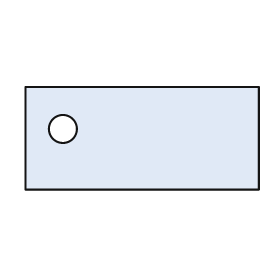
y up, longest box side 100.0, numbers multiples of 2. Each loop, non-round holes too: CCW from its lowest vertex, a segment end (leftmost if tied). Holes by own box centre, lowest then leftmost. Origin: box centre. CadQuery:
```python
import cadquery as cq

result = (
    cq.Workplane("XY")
    .moveTo(-50.0, -22.0)
    .lineTo(50.0, -22.0)
    .lineTo(50.0, 22.0)
    .lineTo(-50.0, 22.0)
    .close()
    .moveTo(-34.0, 4.0)
    .circle(6.0)
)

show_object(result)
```